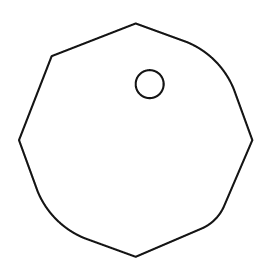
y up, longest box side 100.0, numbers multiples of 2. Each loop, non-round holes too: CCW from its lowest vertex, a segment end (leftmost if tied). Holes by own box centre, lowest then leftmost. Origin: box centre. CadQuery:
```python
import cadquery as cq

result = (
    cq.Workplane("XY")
    .moveTo(0.0, -50.0)
    .lineTo(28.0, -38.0)
    .threePointArc((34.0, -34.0), (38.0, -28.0))
    .lineTo(50.0, 0.0)
    .lineTo(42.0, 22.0)
    .threePointArc((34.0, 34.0), (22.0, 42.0))
    .lineTo(0.0, 50.0)
    .lineTo(-36.0, 36.0)
    .lineTo(-50.0, 0.0)
    .lineTo(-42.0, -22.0)
    .threePointArc((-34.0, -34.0), (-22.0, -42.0))
    .close()
    .moveTo(6.0, 24.0)
    .circle(6.0)
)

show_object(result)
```